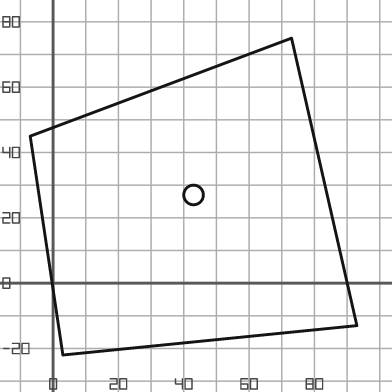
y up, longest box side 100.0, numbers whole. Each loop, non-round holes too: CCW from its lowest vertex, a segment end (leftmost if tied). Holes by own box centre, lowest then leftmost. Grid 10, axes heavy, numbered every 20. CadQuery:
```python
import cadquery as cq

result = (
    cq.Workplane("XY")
    .moveTo(3.0, -22.0)
    .lineTo(93.0, -13.0)
    .lineTo(73.0, 75.0)
    .lineTo(-7.0, 45.0)
    .close()
    .moveTo(43.0, 27.0)
    .circle(3.0)
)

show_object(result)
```